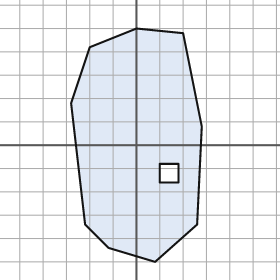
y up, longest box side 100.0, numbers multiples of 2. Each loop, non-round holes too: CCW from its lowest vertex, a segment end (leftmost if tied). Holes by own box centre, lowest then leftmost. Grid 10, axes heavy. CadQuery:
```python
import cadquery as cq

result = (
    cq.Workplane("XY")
    .moveTo(8.0, -50.0)
    .lineTo(26.0, -34.0)
    .lineTo(28.0, 8.0)
    .lineTo(20.0, 48.0)
    .lineTo(0.0, 50.0)
    .lineTo(-20.0, 42.0)
    .lineTo(-28.0, 18.0)
    .lineTo(-22.0, -34.0)
    .lineTo(-12.0, -44.0)
    .close()
    .moveTo(10.0, -16.0)
    .lineTo(18.0, -16.0)
    .lineTo(18.0, -8.0)
    .lineTo(10.0, -8.0)
    .close()
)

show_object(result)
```